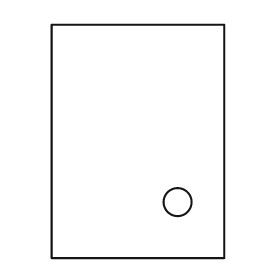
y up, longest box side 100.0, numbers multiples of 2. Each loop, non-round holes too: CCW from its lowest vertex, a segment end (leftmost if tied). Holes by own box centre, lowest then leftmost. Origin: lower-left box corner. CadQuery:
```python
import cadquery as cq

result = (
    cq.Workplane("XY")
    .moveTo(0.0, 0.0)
    .lineTo(74.0, 0.0)
    .lineTo(74.0, 100.0)
    .lineTo(0.0, 100.0)
    .close()
    .moveTo(54.0, 24.0)
    .circle(6.0)
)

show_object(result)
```